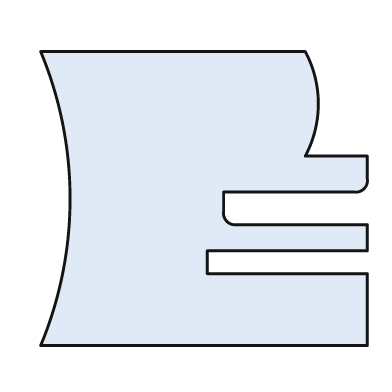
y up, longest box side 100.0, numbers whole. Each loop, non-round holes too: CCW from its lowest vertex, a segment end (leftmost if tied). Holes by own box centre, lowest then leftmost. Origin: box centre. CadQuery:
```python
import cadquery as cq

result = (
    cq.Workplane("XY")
    .moveTo(-50.0, -45.0)
    .lineTo(50.0, -45.0)
    .lineTo(50.0, -23.0)
    .lineTo(1.0, -23.0)
    .lineTo(1.0, -16.0)
    .lineTo(50.0, -16.0)
    .lineTo(50.0, -8.0)
    .lineTo(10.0, -8.0)
    .threePointArc((7.0, -7.0), (6.0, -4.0))
    .lineTo(6.0, 2.0)
    .lineTo(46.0, 2.0)
    .threePointArc((49.0, 3.0), (50.0, 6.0))
    .lineTo(50.0, 13.0)
    .lineTo(31.0, 13.0)
    .threePointArc((35.0, 29.0), (31.0, 45.0))
    .lineTo(-50.0, 45.0)
    .threePointArc((-41.0, 0.0), (-50.0, -45.0))
    .close()
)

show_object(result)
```